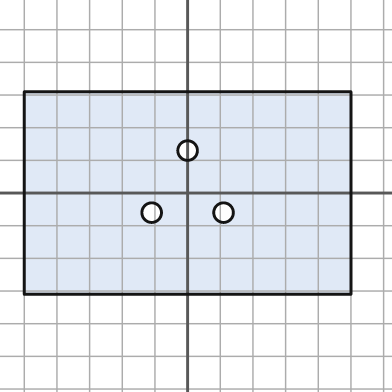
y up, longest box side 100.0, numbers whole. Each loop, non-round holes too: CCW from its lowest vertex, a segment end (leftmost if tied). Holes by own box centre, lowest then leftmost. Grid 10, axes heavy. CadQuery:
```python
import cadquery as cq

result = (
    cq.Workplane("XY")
    .moveTo(-50.0, -31.0)
    .lineTo(50.0, -31.0)
    .lineTo(50.0, 31.0)
    .lineTo(-50.0, 31.0)
    .close()
    .moveTo(-11.0, -6.0)
    .circle(3.0)
    .moveTo(11.0, -6.0)
    .circle(3.0)
    .moveTo(0.0, 13.0)
    .circle(3.0)
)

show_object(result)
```